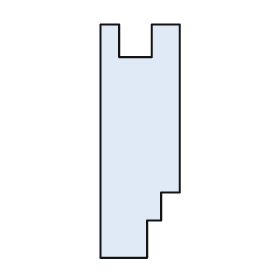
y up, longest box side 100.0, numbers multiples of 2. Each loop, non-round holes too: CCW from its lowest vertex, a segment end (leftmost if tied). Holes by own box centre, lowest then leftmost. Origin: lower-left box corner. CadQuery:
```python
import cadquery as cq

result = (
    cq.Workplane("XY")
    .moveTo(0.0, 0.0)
    .lineTo(20.0, 0.0)
    .lineTo(20.0, 16.0)
    .lineTo(26.0, 16.0)
    .lineTo(26.0, 28.0)
    .lineTo(34.0, 28.0)
    .lineTo(34.0, 100.0)
    .lineTo(22.0, 100.0)
    .lineTo(22.0, 86.0)
    .lineTo(8.0, 86.0)
    .lineTo(8.0, 100.0)
    .lineTo(0.0, 100.0)
    .close()
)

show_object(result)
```